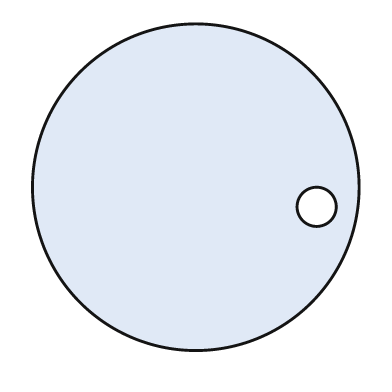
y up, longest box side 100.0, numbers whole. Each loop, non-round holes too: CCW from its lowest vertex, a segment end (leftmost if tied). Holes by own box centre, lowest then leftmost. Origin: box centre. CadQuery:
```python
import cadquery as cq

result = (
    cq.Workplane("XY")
    .moveTo(0.0, 0.0)
    .circle(50.0)
    .moveTo(37.0, -6.0)
    .circle(6.0)
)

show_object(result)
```